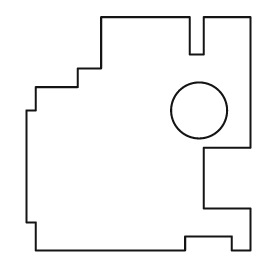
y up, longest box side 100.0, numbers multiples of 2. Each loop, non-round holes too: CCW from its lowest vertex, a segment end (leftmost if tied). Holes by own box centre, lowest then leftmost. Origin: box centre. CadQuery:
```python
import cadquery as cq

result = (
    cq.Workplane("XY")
    .moveTo(-44.0, -50.0)
    .lineTo(20.0, -50.0)
    .lineTo(20.0, -44.0)
    .lineTo(40.0, -44.0)
    .lineTo(40.0, -50.0)
    .lineTo(48.0, -50.0)
    .lineTo(48.0, -32.0)
    .lineTo(28.0, -32.0)
    .lineTo(28.0, -6.0)
    .lineTo(48.0, -6.0)
    .lineTo(48.0, 50.0)
    .lineTo(28.0, 50.0)
    .lineTo(28.0, 34.0)
    .lineTo(22.0, 34.0)
    .lineTo(22.0, 50.0)
    .lineTo(-16.0, 50.0)
    .lineTo(-16.0, 28.0)
    .lineTo(-26.0, 28.0)
    .lineTo(-26.0, 20.0)
    .lineTo(-44.0, 20.0)
    .lineTo(-44.0, 10.0)
    .lineTo(-48.0, 10.0)
    .lineTo(-48.0, -38.0)
    .lineTo(-44.0, -38.0)
    .close()
    .moveTo(26.0, 10.0)
    .circle(12.0)
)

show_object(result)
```